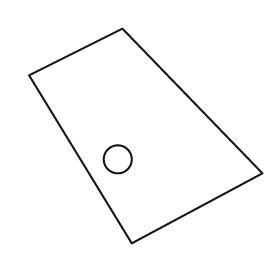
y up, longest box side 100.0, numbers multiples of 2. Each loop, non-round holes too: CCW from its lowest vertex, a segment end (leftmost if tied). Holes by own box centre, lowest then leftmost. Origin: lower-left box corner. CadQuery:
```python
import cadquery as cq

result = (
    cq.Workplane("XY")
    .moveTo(44.0, 0.0)
    .lineTo(100.0, 30.0)
    .lineTo(40.0, 92.0)
    .lineTo(0.0, 72.0)
    .close()
    .moveTo(38.0, 36.0)
    .circle(6.0)
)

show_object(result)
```